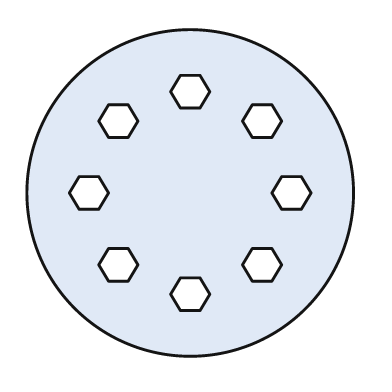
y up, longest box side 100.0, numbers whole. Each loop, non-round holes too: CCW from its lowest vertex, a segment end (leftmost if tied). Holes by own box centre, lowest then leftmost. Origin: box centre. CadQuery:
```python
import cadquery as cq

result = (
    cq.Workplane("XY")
    .moveTo(0.0, 0.0)
    .circle(50.0)
    .moveTo(-3.0, -36.0)
    .lineTo(3.0, -36.0)
    .lineTo(6.0, -31.0)
    .lineTo(3.0, -26.0)
    .lineTo(-3.0, -26.0)
    .lineTo(-6.0, -31.0)
    .close()
    .moveTo(-25.0, -27.0)
    .lineTo(-19.0, -27.0)
    .lineTo(-16.0, -22.0)
    .lineTo(-19.0, -17.0)
    .lineTo(-25.0, -17.0)
    .lineTo(-28.0, -22.0)
    .close()
    .moveTo(19.0, -27.0)
    .lineTo(25.0, -27.0)
    .lineTo(28.0, -22.0)
    .lineTo(25.0, -17.0)
    .lineTo(19.0, -17.0)
    .lineTo(16.0, -22.0)
    .close()
    .moveTo(-34.0, -5.0)
    .lineTo(-28.0, -5.0)
    .lineTo(-25.0, 0.0)
    .lineTo(-28.0, 5.0)
    .lineTo(-34.0, 5.0)
    .lineTo(-37.0, 0.0)
    .close()
    .moveTo(28.0, -5.0)
    .lineTo(34.0, -5.0)
    .lineTo(37.0, 0.0)
    .lineTo(34.0, 5.0)
    .lineTo(28.0, 5.0)
    .lineTo(25.0, 0.0)
    .close()
    .moveTo(-25.0, 17.0)
    .lineTo(-19.0, 17.0)
    .lineTo(-16.0, 22.0)
    .lineTo(-19.0, 27.0)
    .lineTo(-25.0, 27.0)
    .lineTo(-28.0, 22.0)
    .close()
    .moveTo(19.0, 17.0)
    .lineTo(25.0, 17.0)
    .lineTo(28.0, 22.0)
    .lineTo(25.0, 27.0)
    .lineTo(19.0, 27.0)
    .lineTo(16.0, 22.0)
    .close()
    .moveTo(-3.0, 26.0)
    .lineTo(3.0, 26.0)
    .lineTo(6.0, 31.0)
    .lineTo(3.0, 36.0)
    .lineTo(-3.0, 36.0)
    .lineTo(-6.0, 31.0)
    .close()
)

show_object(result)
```